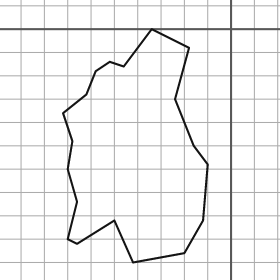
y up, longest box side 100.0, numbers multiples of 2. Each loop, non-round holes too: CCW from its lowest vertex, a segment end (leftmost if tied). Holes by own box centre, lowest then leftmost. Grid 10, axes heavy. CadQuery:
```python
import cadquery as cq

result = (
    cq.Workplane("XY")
    .moveTo(-42.0, -100.0)
    .lineTo(-20.0, -96.0)
    .lineTo(-12.0, -82.0)
    .lineTo(-10.0, -58.0)
    .lineTo(-16.0, -50.0)
    .lineTo(-24.0, -30.0)
    .lineTo(-18.0, -8.0)
    .lineTo(-34.0, 0.0)
    .lineTo(-46.0, -16.0)
    .lineTo(-52.0, -14.0)
    .lineTo(-58.0, -18.0)
    .lineTo(-62.0, -28.0)
    .lineTo(-72.0, -36.0)
    .lineTo(-68.0, -48.0)
    .lineTo(-70.0, -60.0)
    .lineTo(-66.0, -74.0)
    .lineTo(-70.0, -90.0)
    .lineTo(-66.0, -92.0)
    .lineTo(-50.0, -82.0)
    .close()
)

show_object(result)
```